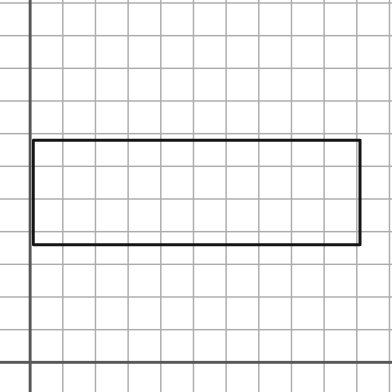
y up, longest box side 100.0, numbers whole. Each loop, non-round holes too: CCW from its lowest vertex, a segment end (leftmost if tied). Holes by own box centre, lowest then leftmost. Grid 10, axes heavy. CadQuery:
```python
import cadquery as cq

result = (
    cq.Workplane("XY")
    .moveTo(1.0, 36.0)
    .lineTo(101.0, 36.0)
    .lineTo(101.0, 68.0)
    .lineTo(1.0, 68.0)
    .close()
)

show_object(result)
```